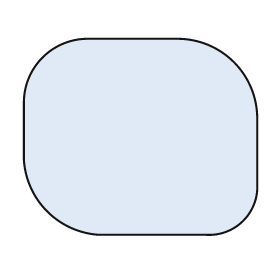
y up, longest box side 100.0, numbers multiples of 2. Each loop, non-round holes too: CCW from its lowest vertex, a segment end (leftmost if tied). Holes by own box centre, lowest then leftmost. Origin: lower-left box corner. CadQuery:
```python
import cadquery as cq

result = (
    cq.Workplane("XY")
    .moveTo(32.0, 0.0)
    .lineTo(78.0, 0.0)
    .threePointArc((94.0, 6.0), (100.0, 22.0))
    .lineTo(100.0, 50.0)
    .threePointArc((90.0, 74.0), (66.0, 84.0))
    .lineTo(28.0, 84.0)
    .threePointArc((8.0, 76.0), (0.0, 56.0))
    .lineTo(0.0, 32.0)
    .threePointArc((10.0, 10.0), (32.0, 0.0))
    .close()
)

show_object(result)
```